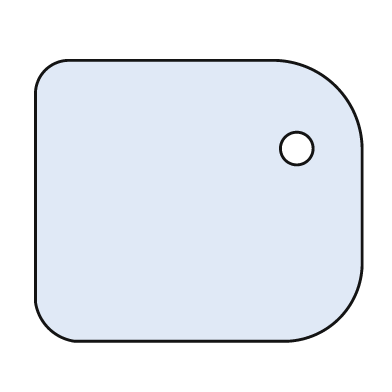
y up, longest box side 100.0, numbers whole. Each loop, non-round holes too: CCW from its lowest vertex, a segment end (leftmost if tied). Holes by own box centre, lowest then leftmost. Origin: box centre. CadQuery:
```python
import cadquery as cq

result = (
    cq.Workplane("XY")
    .moveTo(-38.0, -43.0)
    .lineTo(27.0, -43.0)
    .threePointArc((43.0, -36.0), (50.0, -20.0))
    .lineTo(50.0, 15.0)
    .threePointArc((42.0, 35.0), (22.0, 43.0))
    .lineTo(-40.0, 43.0)
    .threePointArc((-47.0, 40.0), (-50.0, 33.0))
    .lineTo(-50.0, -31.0)
    .threePointArc((-46.0, -39.0), (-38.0, -43.0))
    .close()
    .moveTo(30.0, 16.0)
    .circle(5.0)
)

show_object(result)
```